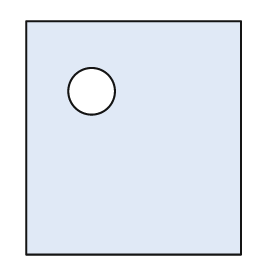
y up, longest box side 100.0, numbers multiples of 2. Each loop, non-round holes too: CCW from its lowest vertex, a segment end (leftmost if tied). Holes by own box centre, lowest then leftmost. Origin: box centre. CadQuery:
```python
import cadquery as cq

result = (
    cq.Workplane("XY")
    .moveTo(-46.0, -50.0)
    .lineTo(46.0, -50.0)
    .lineTo(46.0, 50.0)
    .lineTo(-46.0, 50.0)
    .close()
    .moveTo(-18.0, 20.0)
    .circle(10.0)
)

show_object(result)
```